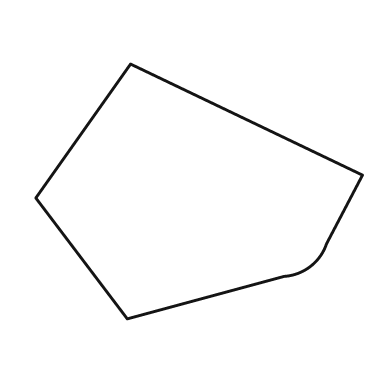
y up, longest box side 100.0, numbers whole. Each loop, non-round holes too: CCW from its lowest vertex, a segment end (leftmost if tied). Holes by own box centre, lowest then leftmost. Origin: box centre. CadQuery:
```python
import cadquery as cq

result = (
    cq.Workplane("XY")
    .moveTo(-22.0, -39.0)
    .lineTo(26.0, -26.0)
    .threePointArc((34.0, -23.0), (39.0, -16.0))
    .lineTo(50.0, 5.0)
    .lineTo(-21.0, 39.0)
    .lineTo(-50.0, -2.0)
    .close()
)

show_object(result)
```